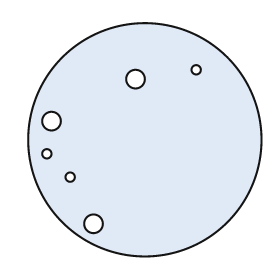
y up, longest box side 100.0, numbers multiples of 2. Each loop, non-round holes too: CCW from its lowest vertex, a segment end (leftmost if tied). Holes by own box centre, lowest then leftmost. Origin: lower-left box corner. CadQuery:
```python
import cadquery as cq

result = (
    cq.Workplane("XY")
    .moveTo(50.0, 50.0)
    .circle(50.0)
    .moveTo(28.0, 14.0)
    .circle(4.0)
    .moveTo(18.0, 34.0)
    .circle(2.0)
    .moveTo(8.0, 44.0)
    .circle(2.0)
    .moveTo(10.0, 58.0)
    .circle(4.0)
    .moveTo(46.0, 76.0)
    .circle(4.0)
    .moveTo(72.0, 80.0)
    .circle(2.0)
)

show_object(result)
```